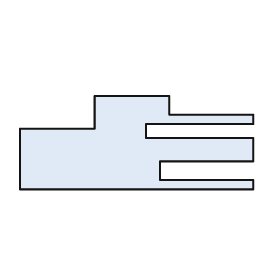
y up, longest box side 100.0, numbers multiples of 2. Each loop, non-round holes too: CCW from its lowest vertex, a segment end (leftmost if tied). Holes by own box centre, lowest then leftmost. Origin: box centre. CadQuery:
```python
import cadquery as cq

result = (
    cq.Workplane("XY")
    .moveTo(-50.0, -20.0)
    .lineTo(50.0, -20.0)
    .lineTo(50.0, -16.0)
    .lineTo(10.0, -16.0)
    .lineTo(10.0, -8.0)
    .lineTo(50.0, -8.0)
    .lineTo(50.0, 2.0)
    .lineTo(4.0, 2.0)
    .lineTo(4.0, 8.0)
    .lineTo(50.0, 8.0)
    .lineTo(50.0, 12.0)
    .lineTo(14.0, 12.0)
    .lineTo(14.0, 20.0)
    .lineTo(-18.0, 20.0)
    .lineTo(-18.0, 6.0)
    .lineTo(-50.0, 6.0)
    .close()
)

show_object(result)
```